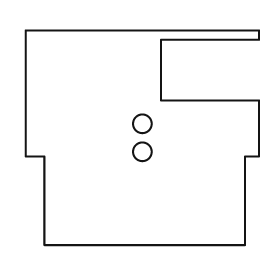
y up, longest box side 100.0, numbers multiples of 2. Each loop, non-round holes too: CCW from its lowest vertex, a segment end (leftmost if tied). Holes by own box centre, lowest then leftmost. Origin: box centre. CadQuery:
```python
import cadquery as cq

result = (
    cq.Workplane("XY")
    .moveTo(-42.0, -46.0)
    .lineTo(44.0, -46.0)
    .lineTo(44.0, -8.0)
    .lineTo(50.0, -8.0)
    .lineTo(50.0, 16.0)
    .lineTo(8.0, 16.0)
    .lineTo(8.0, 42.0)
    .lineTo(50.0, 42.0)
    .lineTo(50.0, 46.0)
    .lineTo(-50.0, 46.0)
    .lineTo(-50.0, -8.0)
    .lineTo(-42.0, -8.0)
    .close()
    .moveTo(0.0, -6.0)
    .circle(4.0)
    .moveTo(0.0, 6.0)
    .circle(4.0)
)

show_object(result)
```